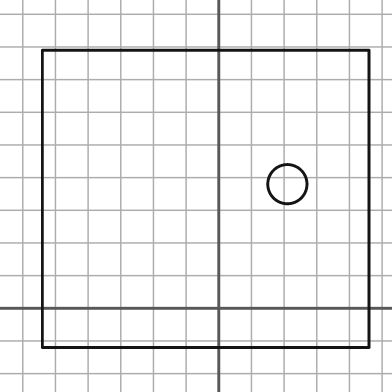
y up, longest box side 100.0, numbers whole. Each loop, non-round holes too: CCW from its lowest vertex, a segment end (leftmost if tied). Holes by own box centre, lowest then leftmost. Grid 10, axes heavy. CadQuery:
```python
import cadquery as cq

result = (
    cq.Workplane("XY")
    .moveTo(-54.0, -12.0)
    .lineTo(46.0, -12.0)
    .lineTo(46.0, 79.0)
    .lineTo(-54.0, 79.0)
    .close()
    .moveTo(21.0, 38.0)
    .circle(6.0)
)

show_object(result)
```